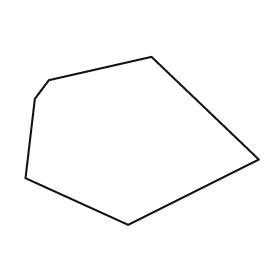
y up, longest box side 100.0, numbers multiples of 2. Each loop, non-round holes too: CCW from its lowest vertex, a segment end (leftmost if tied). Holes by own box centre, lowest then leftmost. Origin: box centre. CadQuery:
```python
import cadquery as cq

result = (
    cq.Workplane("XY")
    .moveTo(-6.0, -36.0)
    .lineTo(50.0, -8.0)
    .lineTo(4.0, 36.0)
    .lineTo(-40.0, 26.0)
    .lineTo(-46.0, 18.0)
    .lineTo(-50.0, -16.0)
    .close()
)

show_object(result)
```